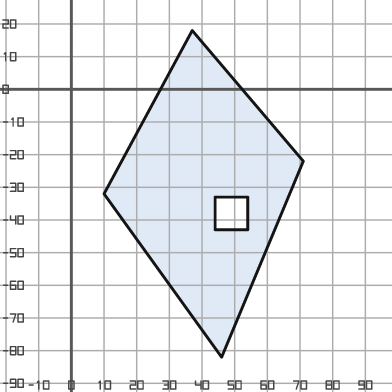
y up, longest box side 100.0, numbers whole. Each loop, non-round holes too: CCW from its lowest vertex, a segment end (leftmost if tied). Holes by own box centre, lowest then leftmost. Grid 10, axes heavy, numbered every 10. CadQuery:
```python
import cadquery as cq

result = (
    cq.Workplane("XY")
    .moveTo(46.0, -82.0)
    .lineTo(71.0, -22.0)
    .lineTo(37.0, 18.0)
    .lineTo(10.0, -32.0)
    .close()
    .moveTo(44.0, -43.0)
    .lineTo(54.0, -43.0)
    .lineTo(54.0, -33.0)
    .lineTo(44.0, -33.0)
    .close()
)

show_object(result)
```